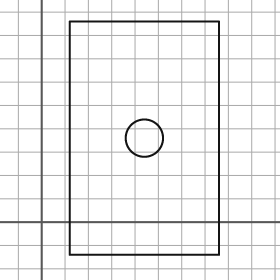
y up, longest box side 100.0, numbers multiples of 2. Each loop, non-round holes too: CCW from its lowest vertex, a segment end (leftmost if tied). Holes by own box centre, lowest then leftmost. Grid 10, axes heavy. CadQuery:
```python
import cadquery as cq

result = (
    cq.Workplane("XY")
    .moveTo(12.0, -14.0)
    .lineTo(76.0, -14.0)
    .lineTo(76.0, 86.0)
    .lineTo(12.0, 86.0)
    .close()
    .moveTo(44.0, 36.0)
    .circle(8.0)
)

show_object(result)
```